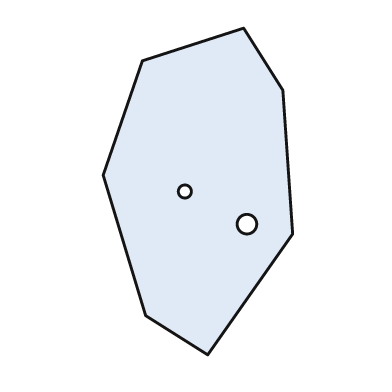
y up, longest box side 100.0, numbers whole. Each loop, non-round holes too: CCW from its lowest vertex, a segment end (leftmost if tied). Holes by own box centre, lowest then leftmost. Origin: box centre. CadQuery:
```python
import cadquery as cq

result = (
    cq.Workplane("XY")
    .moveTo(3.0, -50.0)
    .lineTo(29.0, -13.0)
    .lineTo(26.0, 31.0)
    .lineTo(14.0, 50.0)
    .lineTo(-17.0, 40.0)
    .lineTo(-29.0, 5.0)
    .lineTo(-16.0, -38.0)
    .close()
    .moveTo(15.0, -10.0)
    .circle(3.0)
    .moveTo(-4.0, 0.0)
    .circle(2.0)
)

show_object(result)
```